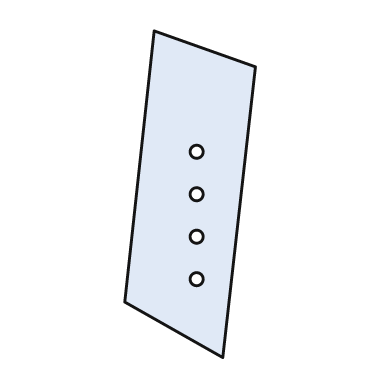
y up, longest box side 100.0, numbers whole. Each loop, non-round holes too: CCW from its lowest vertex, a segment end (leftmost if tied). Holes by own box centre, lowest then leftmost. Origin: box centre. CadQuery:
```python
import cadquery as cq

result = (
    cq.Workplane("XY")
    .moveTo(10.0, -50.0)
    .lineTo(20.0, 39.0)
    .lineTo(-11.0, 50.0)
    .lineTo(-20.0, -33.0)
    .close()
    .moveTo(2.0, -26.0)
    .circle(2.0)
    .moveTo(2.0, -13.0)
    .circle(2.0)
    .moveTo(2.0, 0.0)
    .circle(2.0)
    .moveTo(2.0, 13.0)
    .circle(2.0)
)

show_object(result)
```